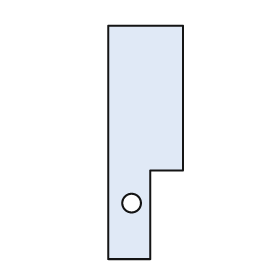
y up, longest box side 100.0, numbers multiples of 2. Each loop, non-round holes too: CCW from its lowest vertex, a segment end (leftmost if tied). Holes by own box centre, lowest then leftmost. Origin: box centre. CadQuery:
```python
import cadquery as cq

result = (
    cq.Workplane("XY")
    .moveTo(-16.0, -50.0)
    .lineTo(2.0, -50.0)
    .lineTo(2.0, -12.0)
    .lineTo(16.0, -12.0)
    .lineTo(16.0, 50.0)
    .lineTo(-16.0, 50.0)
    .close()
    .moveTo(-6.0, -26.0)
    .circle(4.0)
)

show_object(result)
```